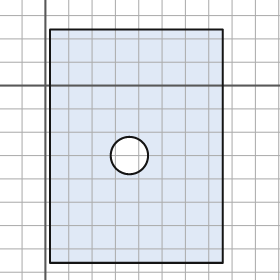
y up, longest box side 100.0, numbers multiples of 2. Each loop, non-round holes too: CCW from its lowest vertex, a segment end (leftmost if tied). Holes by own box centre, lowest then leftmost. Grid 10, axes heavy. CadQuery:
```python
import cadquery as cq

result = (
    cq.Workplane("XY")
    .moveTo(2.0, -76.0)
    .lineTo(76.0, -76.0)
    .lineTo(76.0, 24.0)
    .lineTo(2.0, 24.0)
    .close()
    .moveTo(36.0, -30.0)
    .circle(8.0)
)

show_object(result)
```